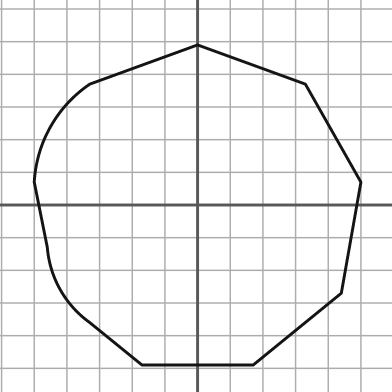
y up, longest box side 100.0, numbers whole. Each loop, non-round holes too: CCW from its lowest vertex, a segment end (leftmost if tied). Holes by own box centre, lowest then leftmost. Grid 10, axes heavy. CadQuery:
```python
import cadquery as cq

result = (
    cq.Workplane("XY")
    .moveTo(-17.0, -49.0)
    .lineTo(17.0, -49.0)
    .lineTo(44.0, -27.0)
    .lineTo(50.0, 7.0)
    .lineTo(33.0, 37.0)
    .lineTo(0.0, 49.0)
    .lineTo(-33.0, 37.0)
    .threePointArc((-45.0, 24.0), (-50.0, 7.0))
    .lineTo(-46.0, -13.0)
    .threePointArc((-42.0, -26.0), (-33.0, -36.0))
    .close()
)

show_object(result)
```